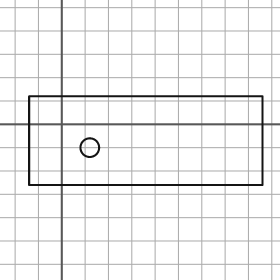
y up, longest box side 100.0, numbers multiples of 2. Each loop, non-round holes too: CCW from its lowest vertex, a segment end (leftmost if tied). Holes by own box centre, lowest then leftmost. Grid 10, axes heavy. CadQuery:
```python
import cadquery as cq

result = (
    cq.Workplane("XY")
    .moveTo(-14.0, -26.0)
    .lineTo(86.0, -26.0)
    .lineTo(86.0, 12.0)
    .lineTo(-14.0, 12.0)
    .close()
    .moveTo(12.0, -10.0)
    .circle(4.0)
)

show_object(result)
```